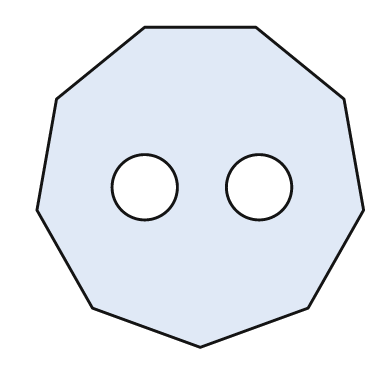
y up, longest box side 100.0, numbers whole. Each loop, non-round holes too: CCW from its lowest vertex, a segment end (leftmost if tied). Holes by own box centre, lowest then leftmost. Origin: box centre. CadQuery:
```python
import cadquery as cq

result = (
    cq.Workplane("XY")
    .moveTo(0.0, -49.0)
    .lineTo(33.0, -37.0)
    .lineTo(50.0, -7.0)
    .lineTo(44.0, 27.0)
    .lineTo(17.0, 49.0)
    .lineTo(-17.0, 49.0)
    .lineTo(-44.0, 27.0)
    .lineTo(-50.0, -7.0)
    .lineTo(-33.0, -37.0)
    .close()
    .moveTo(-17.0, 0.0)
    .circle(10.0)
    .moveTo(18.0, 0.0)
    .circle(10.0)
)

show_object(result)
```